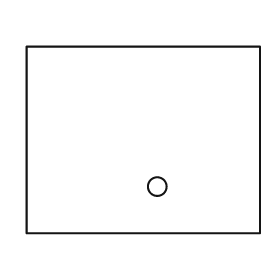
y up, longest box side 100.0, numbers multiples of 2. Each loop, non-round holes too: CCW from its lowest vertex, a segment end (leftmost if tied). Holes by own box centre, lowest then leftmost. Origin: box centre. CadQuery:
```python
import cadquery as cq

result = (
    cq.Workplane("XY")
    .moveTo(-50.0, -40.0)
    .lineTo(50.0, -40.0)
    .lineTo(50.0, 40.0)
    .lineTo(-50.0, 40.0)
    .close()
    .moveTo(6.0, -20.0)
    .circle(4.0)
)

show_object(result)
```